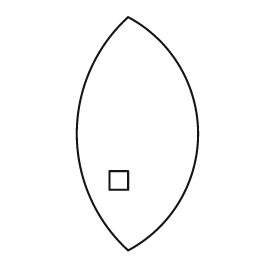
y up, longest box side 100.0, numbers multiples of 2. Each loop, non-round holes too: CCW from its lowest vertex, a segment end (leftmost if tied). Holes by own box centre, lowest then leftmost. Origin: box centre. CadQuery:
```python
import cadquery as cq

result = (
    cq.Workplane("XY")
    .moveTo(-4.0, -50.0)
    .threePointArc((26.0, 0.0), (-4.0, 50.0))
    .threePointArc((-26.0, 0.0), (-4.0, -50.0))
    .close()
    .moveTo(-12.0, -24.0)
    .lineTo(-4.0, -24.0)
    .lineTo(-4.0, -16.0)
    .lineTo(-12.0, -16.0)
    .close()
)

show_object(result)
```